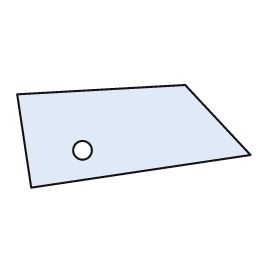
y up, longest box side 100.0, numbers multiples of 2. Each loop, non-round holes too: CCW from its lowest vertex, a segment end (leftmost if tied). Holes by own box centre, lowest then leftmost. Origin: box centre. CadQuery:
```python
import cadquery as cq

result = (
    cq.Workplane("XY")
    .moveTo(-44.0, -22.0)
    .lineTo(50.0, -8.0)
    .lineTo(22.0, 22.0)
    .lineTo(-50.0, 18.0)
    .close()
    .moveTo(-22.0, -6.0)
    .circle(4.0)
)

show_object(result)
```